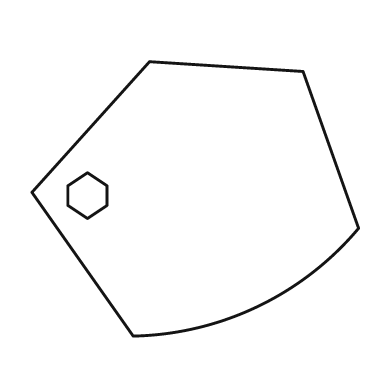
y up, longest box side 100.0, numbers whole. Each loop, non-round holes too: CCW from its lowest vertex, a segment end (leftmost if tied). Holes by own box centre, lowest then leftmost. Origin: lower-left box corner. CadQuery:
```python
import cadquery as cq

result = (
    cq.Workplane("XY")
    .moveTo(31.0, 0.0)
    .threePointArc((69.0, 9.0), (100.0, 33.0))
    .lineTo(83.0, 81.0)
    .lineTo(36.0, 84.0)
    .lineTo(0.0, 44.0)
    .close()
    .moveTo(17.0, 36.0)
    .lineTo(23.0, 40.0)
    .lineTo(23.0, 46.0)
    .lineTo(17.0, 50.0)
    .lineTo(11.0, 46.0)
    .lineTo(11.0, 40.0)
    .close()
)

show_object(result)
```